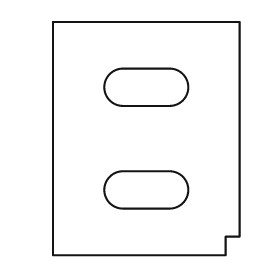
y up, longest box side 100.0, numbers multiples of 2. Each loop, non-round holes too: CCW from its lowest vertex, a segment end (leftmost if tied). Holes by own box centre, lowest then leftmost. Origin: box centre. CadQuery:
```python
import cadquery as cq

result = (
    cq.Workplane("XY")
    .moveTo(-40.0, -50.0)
    .lineTo(34.0, -50.0)
    .lineTo(34.0, -42.0)
    .lineTo(40.0, -42.0)
    .lineTo(40.0, 50.0)
    .lineTo(-40.0, 50.0)
    .close()
    .moveTo(-10.0, -30.0)
    .lineTo(10.0, -30.0)
    .threePointArc((18.0, -22.0), (10.0, -14.0))
    .lineTo(-10.0, -14.0)
    .threePointArc((-18.0, -22.0), (-10.0, -30.0))
    .close()
    .moveTo(-10.0, 14.0)
    .lineTo(10.0, 14.0)
    .threePointArc((18.0, 22.0), (10.0, 30.0))
    .lineTo(-10.0, 30.0)
    .threePointArc((-18.0, 22.0), (-10.0, 14.0))
    .close()
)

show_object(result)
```